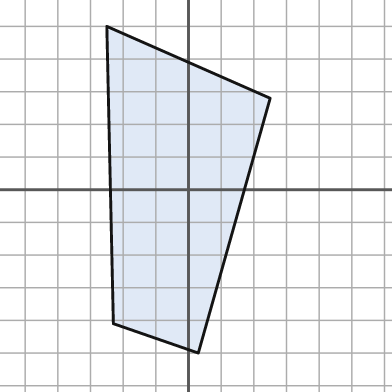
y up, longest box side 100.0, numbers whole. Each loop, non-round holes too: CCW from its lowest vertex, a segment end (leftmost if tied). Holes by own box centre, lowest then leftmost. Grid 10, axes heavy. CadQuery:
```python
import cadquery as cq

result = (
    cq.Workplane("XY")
    .moveTo(3.0, -50.0)
    .lineTo(25.0, 28.0)
    .lineTo(-25.0, 50.0)
    .lineTo(-23.0, -41.0)
    .close()
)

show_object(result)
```